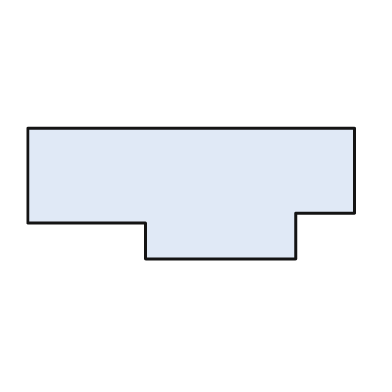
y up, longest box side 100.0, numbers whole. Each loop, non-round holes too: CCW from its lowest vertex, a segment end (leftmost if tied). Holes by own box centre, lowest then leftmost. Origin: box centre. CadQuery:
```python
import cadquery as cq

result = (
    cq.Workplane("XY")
    .moveTo(-14.0, -20.0)
    .lineTo(32.0, -20.0)
    .lineTo(32.0, -6.0)
    .lineTo(50.0, -6.0)
    .lineTo(50.0, 20.0)
    .lineTo(-50.0, 20.0)
    .lineTo(-50.0, -9.0)
    .lineTo(-14.0, -9.0)
    .close()
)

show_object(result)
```